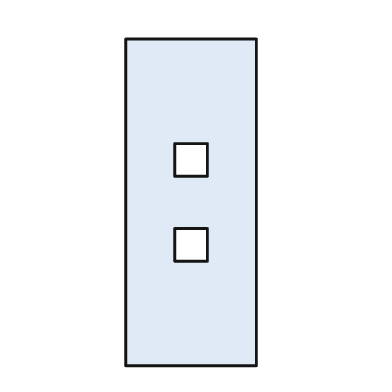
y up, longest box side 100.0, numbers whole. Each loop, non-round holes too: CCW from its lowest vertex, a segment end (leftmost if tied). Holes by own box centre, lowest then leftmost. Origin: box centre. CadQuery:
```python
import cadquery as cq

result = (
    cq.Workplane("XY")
    .moveTo(-20.0, -50.0)
    .lineTo(20.0, -50.0)
    .lineTo(20.0, 50.0)
    .lineTo(-20.0, 50.0)
    .close()
    .moveTo(-5.0, -18.0)
    .lineTo(5.0, -18.0)
    .lineTo(5.0, -8.0)
    .lineTo(-5.0, -8.0)
    .close()
    .moveTo(-5.0, 8.0)
    .lineTo(5.0, 8.0)
    .lineTo(5.0, 18.0)
    .lineTo(-5.0, 18.0)
    .close()
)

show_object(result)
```